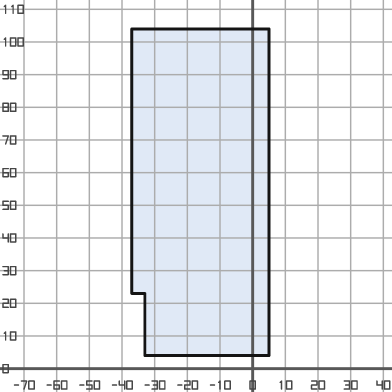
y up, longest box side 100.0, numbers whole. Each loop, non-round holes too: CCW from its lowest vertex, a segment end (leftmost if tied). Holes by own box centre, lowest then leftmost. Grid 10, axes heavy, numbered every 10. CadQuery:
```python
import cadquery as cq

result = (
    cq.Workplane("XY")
    .moveTo(-33.0, 4.0)
    .lineTo(5.0, 4.0)
    .lineTo(5.0, 104.0)
    .lineTo(-37.0, 104.0)
    .lineTo(-37.0, 23.0)
    .lineTo(-33.0, 23.0)
    .close()
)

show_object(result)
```